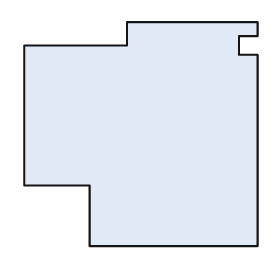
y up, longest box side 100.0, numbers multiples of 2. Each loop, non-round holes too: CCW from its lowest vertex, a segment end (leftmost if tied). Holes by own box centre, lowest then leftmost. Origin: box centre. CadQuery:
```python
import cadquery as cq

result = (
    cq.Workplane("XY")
    .moveTo(-22.0, -48.0)
    .lineTo(50.0, -48.0)
    .lineTo(50.0, 34.0)
    .lineTo(42.0, 34.0)
    .lineTo(42.0, 42.0)
    .lineTo(50.0, 42.0)
    .lineTo(50.0, 48.0)
    .lineTo(-6.0, 48.0)
    .lineTo(-6.0, 38.0)
    .lineTo(-50.0, 38.0)
    .lineTo(-50.0, -22.0)
    .lineTo(-22.0, -22.0)
    .close()
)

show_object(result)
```